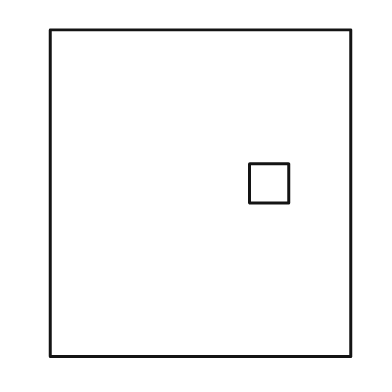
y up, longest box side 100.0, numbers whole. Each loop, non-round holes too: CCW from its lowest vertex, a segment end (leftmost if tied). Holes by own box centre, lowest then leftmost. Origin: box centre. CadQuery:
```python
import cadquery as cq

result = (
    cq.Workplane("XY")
    .moveTo(-46.0, -50.0)
    .lineTo(46.0, -50.0)
    .lineTo(46.0, 50.0)
    .lineTo(-46.0, 50.0)
    .close()
    .moveTo(15.0, -3.0)
    .lineTo(27.0, -3.0)
    .lineTo(27.0, 9.0)
    .lineTo(15.0, 9.0)
    .close()
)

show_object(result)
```